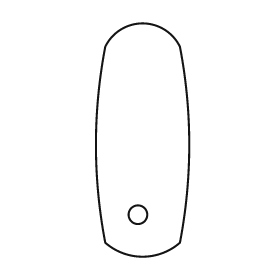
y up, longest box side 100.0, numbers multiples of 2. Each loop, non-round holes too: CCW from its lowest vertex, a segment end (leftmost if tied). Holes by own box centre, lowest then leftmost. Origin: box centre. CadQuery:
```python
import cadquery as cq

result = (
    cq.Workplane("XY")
    .moveTo(-16.0, -44.0)
    .threePointArc((0.0, -50.0), (16.0, -44.0))
    .threePointArc((20.0, -2.0), (16.0, 40.0))
    .threePointArc((0.0, 50.0), (-16.0, 40.0))
    .threePointArc((-20.0, -2.0), (-16.0, -44.0))
    .close()
    .moveTo(-2.0, -32.0)
    .circle(4.0)
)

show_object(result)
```